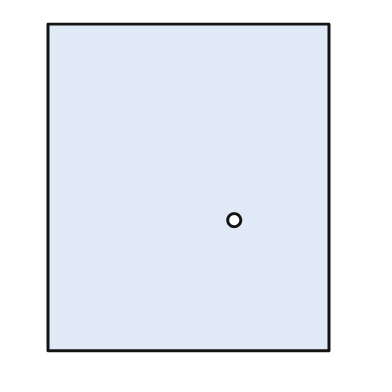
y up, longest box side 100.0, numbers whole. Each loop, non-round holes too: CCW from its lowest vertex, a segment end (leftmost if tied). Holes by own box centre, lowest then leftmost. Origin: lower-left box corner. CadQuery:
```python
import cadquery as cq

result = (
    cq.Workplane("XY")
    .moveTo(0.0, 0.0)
    .lineTo(86.0, 0.0)
    .lineTo(86.0, 100.0)
    .lineTo(0.0, 100.0)
    .close()
    .moveTo(57.0, 40.0)
    .circle(2.0)
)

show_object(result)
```